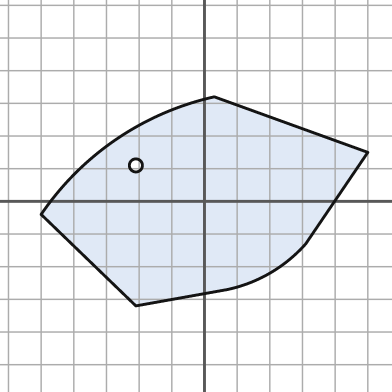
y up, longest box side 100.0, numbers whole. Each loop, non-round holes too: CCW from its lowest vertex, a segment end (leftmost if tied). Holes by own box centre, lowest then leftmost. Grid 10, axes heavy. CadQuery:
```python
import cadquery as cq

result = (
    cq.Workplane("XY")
    .moveTo(-21.0, -32.0)
    .lineTo(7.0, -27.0)
    .threePointArc((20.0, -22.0), (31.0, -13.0))
    .lineTo(50.0, 15.0)
    .lineTo(3.0, 32.0)
    .threePointArc((-27.0, 19.0), (-50.0, -4.0))
    .close()
    .moveTo(-21.0, 11.0)
    .circle(2.0)
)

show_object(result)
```